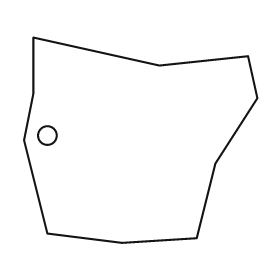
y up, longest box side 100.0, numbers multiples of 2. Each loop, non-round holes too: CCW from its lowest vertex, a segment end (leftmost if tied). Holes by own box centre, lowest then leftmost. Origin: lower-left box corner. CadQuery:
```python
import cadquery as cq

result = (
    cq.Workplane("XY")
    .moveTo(42.0, 0.0)
    .lineTo(74.0, 2.0)
    .lineTo(82.0, 34.0)
    .lineTo(100.0, 62.0)
    .lineTo(96.0, 80.0)
    .lineTo(58.0, 76.0)
    .lineTo(4.0, 88.0)
    .lineTo(4.0, 64.0)
    .lineTo(0.0, 44.0)
    .lineTo(10.0, 4.0)
    .close()
    .moveTo(10.0, 46.0)
    .circle(4.0)
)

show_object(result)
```